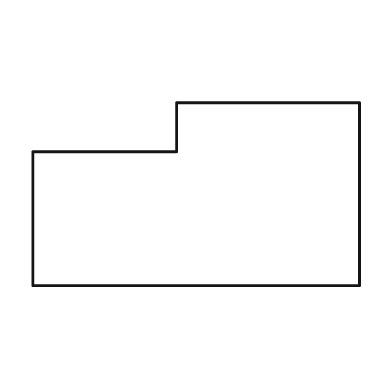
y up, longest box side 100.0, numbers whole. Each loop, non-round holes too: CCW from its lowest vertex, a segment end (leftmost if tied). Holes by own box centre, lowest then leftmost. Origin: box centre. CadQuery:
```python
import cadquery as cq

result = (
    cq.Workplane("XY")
    .moveTo(-50.0, -28.0)
    .lineTo(50.0, -28.0)
    .lineTo(50.0, 28.0)
    .lineTo(-6.0, 28.0)
    .lineTo(-6.0, 13.0)
    .lineTo(-50.0, 13.0)
    .close()
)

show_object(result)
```